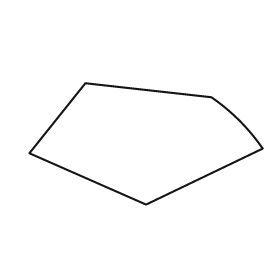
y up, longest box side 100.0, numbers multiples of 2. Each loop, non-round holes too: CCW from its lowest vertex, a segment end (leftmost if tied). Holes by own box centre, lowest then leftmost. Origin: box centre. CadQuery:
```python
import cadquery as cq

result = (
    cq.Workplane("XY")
    .moveTo(0.0, -26.0)
    .lineTo(50.0, -2.0)
    .threePointArc((40.0, 10.0), (28.0, 20.0))
    .lineTo(-26.0, 26.0)
    .lineTo(-50.0, -4.0)
    .close()
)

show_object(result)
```